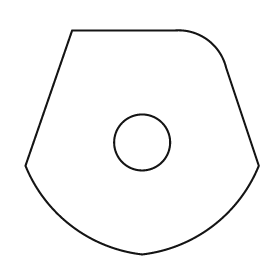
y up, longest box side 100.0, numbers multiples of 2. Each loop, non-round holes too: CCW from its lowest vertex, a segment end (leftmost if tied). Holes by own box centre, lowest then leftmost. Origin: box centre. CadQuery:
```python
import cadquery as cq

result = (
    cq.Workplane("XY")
    .moveTo(0.0, -48.0)
    .threePointArc((30.0, -36.0), (50.0, -10.0))
    .lineTo(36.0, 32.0)
    .threePointArc((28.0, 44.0), (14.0, 48.0))
    .lineTo(-30.0, 48.0)
    .lineTo(-50.0, -10.0)
    .threePointArc((-30.0, -36.0), (0.0, -48.0))
    .close()
    .moveTo(0.0, 0.0)
    .circle(12.0)
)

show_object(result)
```